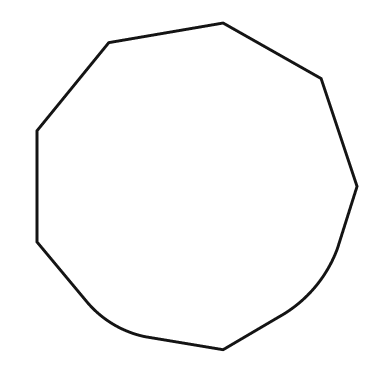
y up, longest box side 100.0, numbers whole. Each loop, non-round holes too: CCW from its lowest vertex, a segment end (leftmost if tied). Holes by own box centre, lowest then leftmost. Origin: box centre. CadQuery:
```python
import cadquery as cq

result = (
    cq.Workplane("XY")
    .moveTo(8.0, -50.0)
    .lineTo(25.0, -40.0)
    .threePointArc((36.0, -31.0), (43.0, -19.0))
    .lineTo(49.0, 0.0)
    .lineTo(38.0, 33.0)
    .lineTo(8.0, 50.0)
    .lineTo(-27.0, 44.0)
    .lineTo(-49.0, 17.0)
    .lineTo(-49.0, -17.0)
    .lineTo(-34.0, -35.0)
    .threePointArc((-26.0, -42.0), (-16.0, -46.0))
    .close()
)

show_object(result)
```